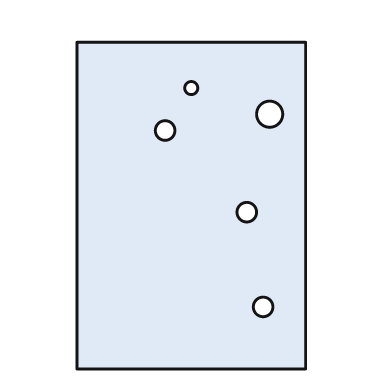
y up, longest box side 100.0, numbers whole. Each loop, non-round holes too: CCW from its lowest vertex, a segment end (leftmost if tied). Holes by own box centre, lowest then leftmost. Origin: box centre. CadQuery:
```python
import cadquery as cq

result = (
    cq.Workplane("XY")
    .moveTo(-35.0, -50.0)
    .lineTo(35.0, -50.0)
    .lineTo(35.0, 50.0)
    .lineTo(-35.0, 50.0)
    .close()
    .moveTo(22.0, -31.0)
    .circle(3.0)
    .moveTo(17.0, -2.0)
    .circle(3.0)
    .moveTo(-8.0, 23.0)
    .circle(3.0)
    .moveTo(24.0, 28.0)
    .circle(4.0)
    .moveTo(0.0, 36.0)
    .circle(2.0)
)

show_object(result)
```